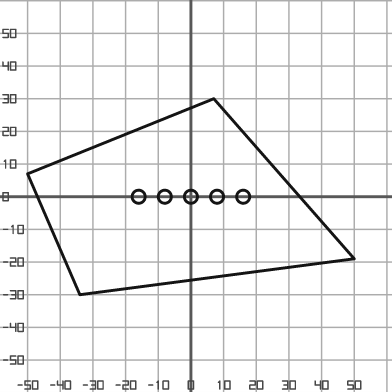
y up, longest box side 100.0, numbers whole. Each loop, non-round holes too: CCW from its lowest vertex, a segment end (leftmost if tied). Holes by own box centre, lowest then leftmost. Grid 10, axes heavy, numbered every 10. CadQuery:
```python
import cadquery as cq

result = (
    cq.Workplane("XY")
    .moveTo(-34.0, -30.0)
    .lineTo(50.0, -19.0)
    .lineTo(7.0, 30.0)
    .lineTo(-50.0, 7.0)
    .close()
    .moveTo(-16.0, 0.0)
    .circle(2.0)
    .moveTo(-8.0, 0.0)
    .circle(2.0)
    .moveTo(0.0, 0.0)
    .circle(2.0)
    .moveTo(8.0, 0.0)
    .circle(2.0)
    .moveTo(16.0, 0.0)
    .circle(2.0)
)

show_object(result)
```